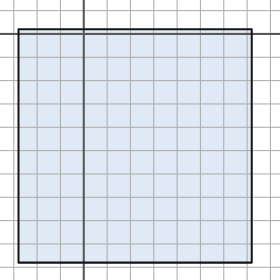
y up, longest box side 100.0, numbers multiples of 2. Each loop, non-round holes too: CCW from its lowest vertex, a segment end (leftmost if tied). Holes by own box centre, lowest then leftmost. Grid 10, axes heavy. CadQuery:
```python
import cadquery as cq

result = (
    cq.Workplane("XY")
    .moveTo(-28.0, -98.0)
    .lineTo(72.0, -98.0)
    .lineTo(72.0, 2.0)
    .lineTo(-28.0, 2.0)
    .close()
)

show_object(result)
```